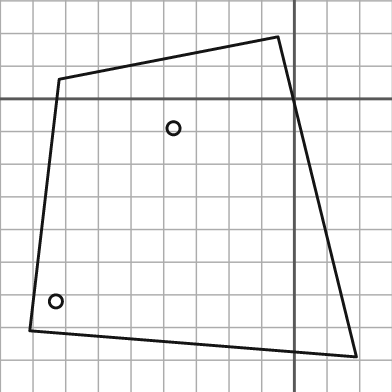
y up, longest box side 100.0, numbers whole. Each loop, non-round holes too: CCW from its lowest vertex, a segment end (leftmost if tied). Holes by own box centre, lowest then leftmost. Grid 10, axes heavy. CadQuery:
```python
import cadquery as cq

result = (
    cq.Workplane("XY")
    .moveTo(19.0, -79.0)
    .lineTo(-5.0, 19.0)
    .lineTo(-72.0, 6.0)
    .lineTo(-81.0, -71.0)
    .close()
    .moveTo(-73.0, -62.0)
    .circle(2.0)
    .moveTo(-37.0, -9.0)
    .circle(2.0)
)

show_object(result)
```